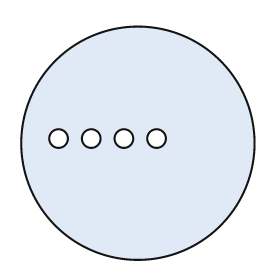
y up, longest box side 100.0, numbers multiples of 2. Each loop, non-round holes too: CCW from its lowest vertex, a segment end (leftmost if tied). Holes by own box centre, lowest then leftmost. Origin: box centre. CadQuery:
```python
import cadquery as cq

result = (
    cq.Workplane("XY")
    .moveTo(0.0, 0.0)
    .circle(50.0)
    .moveTo(-34.0, 2.0)
    .circle(4.0)
    .moveTo(-20.0, 2.0)
    .circle(4.0)
    .moveTo(-6.0, 2.0)
    .circle(4.0)
    .moveTo(8.0, 2.0)
    .circle(4.0)
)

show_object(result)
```